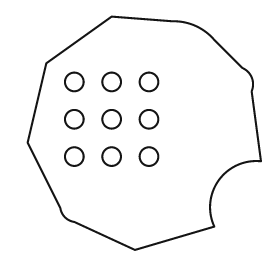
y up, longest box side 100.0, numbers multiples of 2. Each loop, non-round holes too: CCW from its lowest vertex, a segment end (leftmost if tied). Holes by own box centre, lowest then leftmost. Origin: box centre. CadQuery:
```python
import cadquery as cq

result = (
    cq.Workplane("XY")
    .moveTo(-4.0, -50.0)
    .lineTo(30.0, -40.0)
    .threePointArc((32.0, -20.0), (50.0, -12.0))
    .lineTo(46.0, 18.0)
    .threePointArc((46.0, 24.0), (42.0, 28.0))
    .lineTo(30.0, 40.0)
    .threePointArc((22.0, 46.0), (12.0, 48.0))
    .lineTo(-14.0, 50.0)
    .lineTo(-42.0, 30.0)
    .lineTo(-50.0, -4.0)
    .lineTo(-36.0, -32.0)
    .threePointArc((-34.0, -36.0), (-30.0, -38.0))
    .close()
    .moveTo(-30.0, -10.0)
    .circle(4.0)
    .moveTo(-14.0, -10.0)
    .circle(4.0)
    .moveTo(2.0, -10.0)
    .circle(4.0)
    .moveTo(-30.0, 6.0)
    .circle(4.0)
    .moveTo(-14.0, 6.0)
    .circle(4.0)
    .moveTo(2.0, 6.0)
    .circle(4.0)
    .moveTo(-30.0, 22.0)
    .circle(4.0)
    .moveTo(-14.0, 22.0)
    .circle(4.0)
    .moveTo(2.0, 22.0)
    .circle(4.0)
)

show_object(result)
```